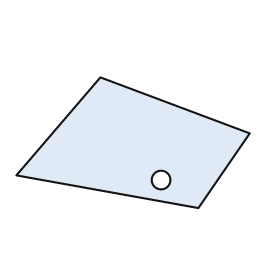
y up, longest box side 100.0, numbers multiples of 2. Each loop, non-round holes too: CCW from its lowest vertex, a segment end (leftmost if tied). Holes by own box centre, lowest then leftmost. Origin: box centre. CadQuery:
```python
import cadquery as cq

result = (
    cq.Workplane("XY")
    .moveTo(28.0, -28.0)
    .lineTo(50.0, 4.0)
    .lineTo(-14.0, 28.0)
    .lineTo(-50.0, -14.0)
    .close()
    .moveTo(12.0, -16.0)
    .circle(4.0)
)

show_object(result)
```